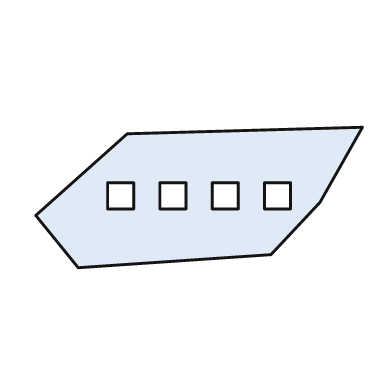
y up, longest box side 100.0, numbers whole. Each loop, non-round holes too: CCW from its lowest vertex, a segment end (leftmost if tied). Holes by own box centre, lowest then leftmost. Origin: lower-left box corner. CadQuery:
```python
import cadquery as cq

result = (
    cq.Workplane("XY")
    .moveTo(13.0, 0.0)
    .lineTo(72.0, 4.0)
    .lineTo(87.0, 20.0)
    .lineTo(100.0, 43.0)
    .lineTo(28.0, 41.0)
    .lineTo(0.0, 16.0)
    .close()
    .moveTo(22.0, 18.0)
    .lineTo(30.0, 18.0)
    .lineTo(30.0, 26.0)
    .lineTo(22.0, 26.0)
    .close()
    .moveTo(38.0, 18.0)
    .lineTo(46.0, 18.0)
    .lineTo(46.0, 26.0)
    .lineTo(38.0, 26.0)
    .close()
    .moveTo(54.0, 18.0)
    .lineTo(62.0, 18.0)
    .lineTo(62.0, 26.0)
    .lineTo(54.0, 26.0)
    .close()
    .moveTo(70.0, 18.0)
    .lineTo(78.0, 18.0)
    .lineTo(78.0, 26.0)
    .lineTo(70.0, 26.0)
    .close()
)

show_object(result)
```